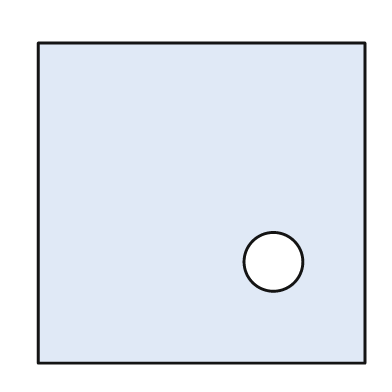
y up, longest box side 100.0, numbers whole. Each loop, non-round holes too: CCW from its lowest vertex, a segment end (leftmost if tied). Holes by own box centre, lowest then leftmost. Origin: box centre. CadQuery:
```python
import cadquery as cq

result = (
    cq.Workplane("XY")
    .moveTo(-50.0, -49.0)
    .lineTo(50.0, -49.0)
    .lineTo(50.0, 49.0)
    .lineTo(-50.0, 49.0)
    .close()
    .moveTo(22.0, -18.0)
    .circle(9.0)
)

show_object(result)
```